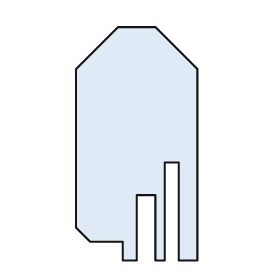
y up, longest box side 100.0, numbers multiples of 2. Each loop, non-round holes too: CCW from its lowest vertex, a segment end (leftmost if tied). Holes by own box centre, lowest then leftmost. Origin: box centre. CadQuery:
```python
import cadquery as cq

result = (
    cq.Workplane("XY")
    .moveTo(-6.0, -50.0)
    .lineTo(0.0, -50.0)
    .lineTo(0.0, -22.0)
    .lineTo(8.0, -22.0)
    .lineTo(8.0, -50.0)
    .lineTo(12.0, -50.0)
    .lineTo(12.0, -8.0)
    .lineTo(18.0, -8.0)
    .lineTo(18.0, -50.0)
    .lineTo(26.0, -50.0)
    .lineTo(26.0, 32.0)
    .lineTo(8.0, 50.0)
    .lineTo(-8.0, 50.0)
    .lineTo(-26.0, 32.0)
    .lineTo(-26.0, -36.0)
    .lineTo(-20.0, -42.0)
    .lineTo(-6.0, -42.0)
    .close()
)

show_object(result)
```